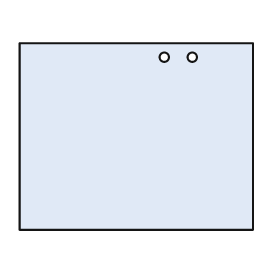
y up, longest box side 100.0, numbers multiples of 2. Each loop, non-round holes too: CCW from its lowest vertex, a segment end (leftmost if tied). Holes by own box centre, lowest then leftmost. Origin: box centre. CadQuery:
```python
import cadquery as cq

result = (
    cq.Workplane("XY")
    .moveTo(-50.0, -40.0)
    .lineTo(50.0, -40.0)
    .lineTo(50.0, 40.0)
    .lineTo(-50.0, 40.0)
    .close()
    .moveTo(12.0, 34.0)
    .circle(2.0)
    .moveTo(24.0, 34.0)
    .circle(2.0)
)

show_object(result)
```